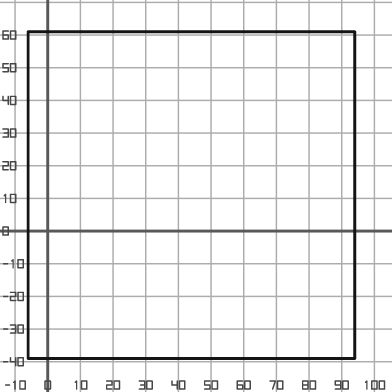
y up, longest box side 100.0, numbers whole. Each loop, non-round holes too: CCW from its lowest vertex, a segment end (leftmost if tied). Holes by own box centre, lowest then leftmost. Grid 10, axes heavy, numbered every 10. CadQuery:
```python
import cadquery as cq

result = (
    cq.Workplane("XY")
    .moveTo(-6.0, -39.0)
    .lineTo(94.0, -39.0)
    .lineTo(94.0, 61.0)
    .lineTo(-6.0, 61.0)
    .close()
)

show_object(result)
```